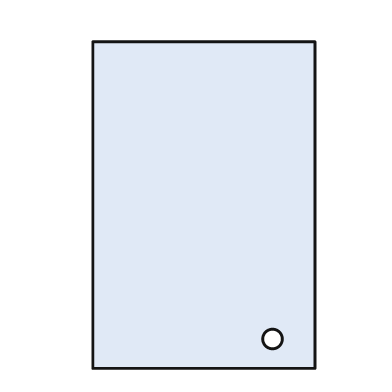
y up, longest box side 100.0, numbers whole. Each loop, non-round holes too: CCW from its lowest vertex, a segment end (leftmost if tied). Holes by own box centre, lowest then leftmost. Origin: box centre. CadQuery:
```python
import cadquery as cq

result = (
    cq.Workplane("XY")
    .moveTo(-34.0, -50.0)
    .lineTo(34.0, -50.0)
    .lineTo(34.0, 50.0)
    .lineTo(-34.0, 50.0)
    .close()
    .moveTo(21.0, -41.0)
    .circle(3.0)
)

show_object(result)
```